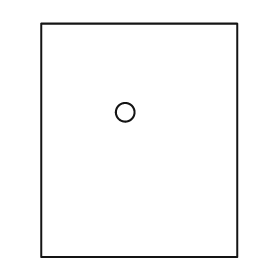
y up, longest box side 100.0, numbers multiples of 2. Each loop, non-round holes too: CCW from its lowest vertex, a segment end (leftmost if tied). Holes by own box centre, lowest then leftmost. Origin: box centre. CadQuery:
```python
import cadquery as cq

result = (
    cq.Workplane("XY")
    .moveTo(-42.0, -50.0)
    .lineTo(42.0, -50.0)
    .lineTo(42.0, 50.0)
    .lineTo(-42.0, 50.0)
    .close()
    .moveTo(-6.0, 12.0)
    .circle(4.0)
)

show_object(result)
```